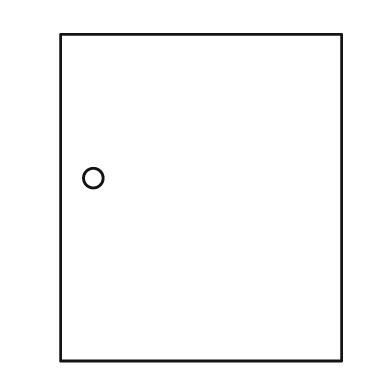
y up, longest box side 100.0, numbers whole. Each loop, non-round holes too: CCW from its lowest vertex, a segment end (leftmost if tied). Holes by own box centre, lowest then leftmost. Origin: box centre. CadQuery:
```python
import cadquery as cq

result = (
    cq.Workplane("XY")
    .moveTo(-43.0, -50.0)
    .lineTo(43.0, -50.0)
    .lineTo(43.0, 50.0)
    .lineTo(-43.0, 50.0)
    .close()
    .moveTo(-33.0, 6.0)
    .circle(3.0)
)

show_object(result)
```